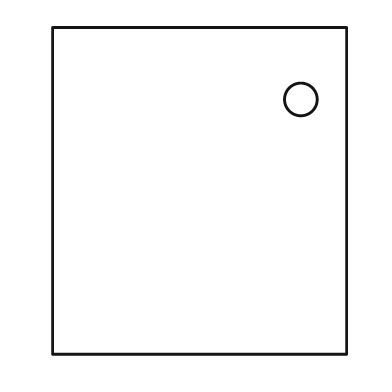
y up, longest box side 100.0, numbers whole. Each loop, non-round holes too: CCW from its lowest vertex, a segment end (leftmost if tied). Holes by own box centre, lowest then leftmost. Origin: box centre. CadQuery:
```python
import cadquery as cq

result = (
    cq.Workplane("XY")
    .moveTo(-45.0, -50.0)
    .lineTo(45.0, -50.0)
    .lineTo(45.0, 50.0)
    .lineTo(-45.0, 50.0)
    .close()
    .moveTo(31.0, 28.0)
    .circle(5.0)
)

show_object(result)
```